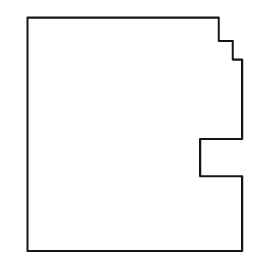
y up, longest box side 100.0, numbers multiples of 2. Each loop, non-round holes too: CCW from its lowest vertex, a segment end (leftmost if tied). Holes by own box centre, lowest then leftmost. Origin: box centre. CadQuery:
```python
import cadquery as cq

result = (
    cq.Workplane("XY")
    .moveTo(-46.0, -50.0)
    .lineTo(46.0, -50.0)
    .lineTo(46.0, -18.0)
    .lineTo(28.0, -18.0)
    .lineTo(28.0, -2.0)
    .lineTo(46.0, -2.0)
    .lineTo(46.0, 32.0)
    .lineTo(42.0, 32.0)
    .lineTo(42.0, 40.0)
    .lineTo(36.0, 40.0)
    .lineTo(36.0, 50.0)
    .lineTo(-46.0, 50.0)
    .close()
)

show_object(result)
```